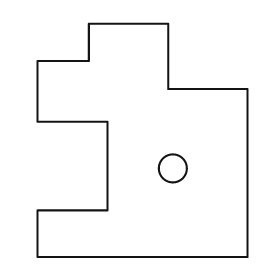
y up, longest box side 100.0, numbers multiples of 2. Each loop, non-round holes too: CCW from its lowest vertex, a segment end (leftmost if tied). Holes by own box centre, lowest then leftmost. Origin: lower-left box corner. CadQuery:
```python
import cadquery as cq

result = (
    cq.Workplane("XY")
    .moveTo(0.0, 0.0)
    .lineTo(90.0, 0.0)
    .lineTo(90.0, 72.0)
    .lineTo(56.0, 72.0)
    .lineTo(56.0, 100.0)
    .lineTo(22.0, 100.0)
    .lineTo(22.0, 84.0)
    .lineTo(0.0, 84.0)
    .lineTo(0.0, 58.0)
    .lineTo(30.0, 58.0)
    .lineTo(30.0, 20.0)
    .lineTo(0.0, 20.0)
    .close()
    .moveTo(58.0, 38.0)
    .circle(6.0)
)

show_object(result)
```